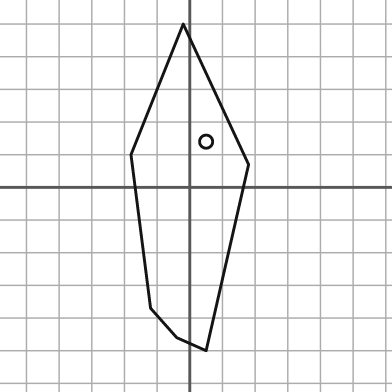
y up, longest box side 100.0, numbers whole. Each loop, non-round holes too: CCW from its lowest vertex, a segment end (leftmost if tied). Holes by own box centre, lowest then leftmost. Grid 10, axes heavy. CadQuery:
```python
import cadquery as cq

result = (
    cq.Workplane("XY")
    .moveTo(5.0, -50.0)
    .lineTo(18.0, 7.0)
    .lineTo(-2.0, 50.0)
    .lineTo(-18.0, 10.0)
    .lineTo(-12.0, -37.0)
    .lineTo(-4.0, -46.0)
    .close()
    .moveTo(5.0, 14.0)
    .circle(2.0)
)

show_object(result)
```